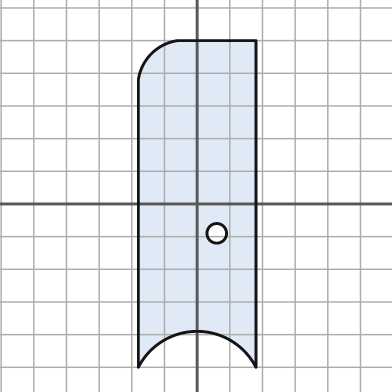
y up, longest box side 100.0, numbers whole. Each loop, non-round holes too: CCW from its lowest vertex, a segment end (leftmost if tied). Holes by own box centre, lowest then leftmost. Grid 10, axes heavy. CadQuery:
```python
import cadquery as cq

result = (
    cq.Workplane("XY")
    .moveTo(-18.0, -50.0)
    .threePointArc((0.0, -39.0), (18.0, -50.0))
    .lineTo(18.0, 50.0)
    .lineTo(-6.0, 50.0)
    .threePointArc((-14.0, 46.0), (-18.0, 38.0))
    .close()
    .moveTo(6.0, -9.0)
    .circle(3.0)
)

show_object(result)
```